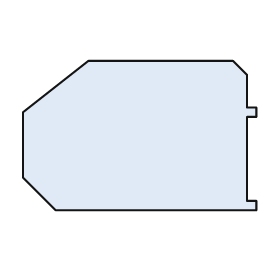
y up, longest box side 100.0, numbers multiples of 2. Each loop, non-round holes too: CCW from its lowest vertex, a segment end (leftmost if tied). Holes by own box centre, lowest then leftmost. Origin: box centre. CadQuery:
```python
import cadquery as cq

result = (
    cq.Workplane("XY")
    .moveTo(-36.0, -32.0)
    .lineTo(50.0, -32.0)
    .lineTo(50.0, -28.0)
    .lineTo(46.0, -28.0)
    .lineTo(46.0, 8.0)
    .lineTo(50.0, 8.0)
    .lineTo(50.0, 12.0)
    .lineTo(46.0, 12.0)
    .lineTo(46.0, 26.0)
    .lineTo(40.0, 32.0)
    .lineTo(-22.0, 32.0)
    .lineTo(-50.0, 10.0)
    .lineTo(-50.0, -18.0)
    .close()
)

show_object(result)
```